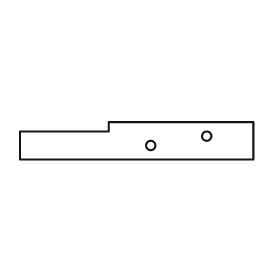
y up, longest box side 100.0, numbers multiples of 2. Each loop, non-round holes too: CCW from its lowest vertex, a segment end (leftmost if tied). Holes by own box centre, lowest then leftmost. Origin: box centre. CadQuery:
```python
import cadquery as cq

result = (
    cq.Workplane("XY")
    .moveTo(-50.0, -8.0)
    .lineTo(50.0, -8.0)
    .lineTo(50.0, 8.0)
    .lineTo(-12.0, 8.0)
    .lineTo(-12.0, 4.0)
    .lineTo(-50.0, 4.0)
    .close()
    .moveTo(6.0, -2.0)
    .circle(2.0)
    .moveTo(30.0, 2.0)
    .circle(2.0)
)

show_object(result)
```